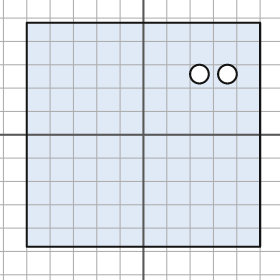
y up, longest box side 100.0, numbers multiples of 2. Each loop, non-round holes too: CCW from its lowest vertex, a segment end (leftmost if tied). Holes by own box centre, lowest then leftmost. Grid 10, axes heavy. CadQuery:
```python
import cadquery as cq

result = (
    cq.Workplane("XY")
    .moveTo(-50.0, -48.0)
    .lineTo(50.0, -48.0)
    .lineTo(50.0, 48.0)
    .lineTo(-50.0, 48.0)
    .close()
    .moveTo(24.0, 26.0)
    .circle(4.0)
    .moveTo(36.0, 26.0)
    .circle(4.0)
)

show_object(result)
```